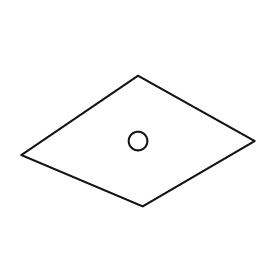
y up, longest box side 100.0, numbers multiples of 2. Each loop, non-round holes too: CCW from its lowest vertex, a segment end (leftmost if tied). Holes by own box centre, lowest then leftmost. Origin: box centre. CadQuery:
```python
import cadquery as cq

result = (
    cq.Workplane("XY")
    .moveTo(2.0, -28.0)
    .lineTo(50.0, 0.0)
    .lineTo(0.0, 28.0)
    .lineTo(-50.0, -6.0)
    .close()
    .moveTo(0.0, 0.0)
    .circle(4.0)
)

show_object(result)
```